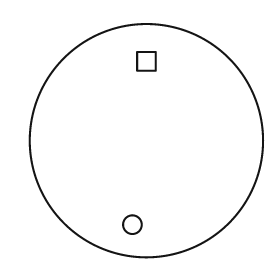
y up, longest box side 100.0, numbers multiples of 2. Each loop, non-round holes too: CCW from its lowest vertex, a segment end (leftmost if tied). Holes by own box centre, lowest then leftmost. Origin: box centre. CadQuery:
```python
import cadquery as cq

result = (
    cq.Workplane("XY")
    .moveTo(0.0, 0.0)
    .circle(50.0)
    .moveTo(-6.0, -36.0)
    .circle(4.0)
    .moveTo(-4.0, 30.0)
    .lineTo(4.0, 30.0)
    .lineTo(4.0, 38.0)
    .lineTo(-4.0, 38.0)
    .close()
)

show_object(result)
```